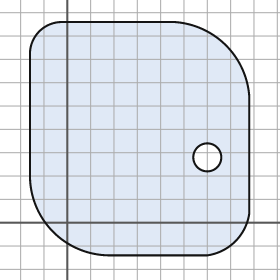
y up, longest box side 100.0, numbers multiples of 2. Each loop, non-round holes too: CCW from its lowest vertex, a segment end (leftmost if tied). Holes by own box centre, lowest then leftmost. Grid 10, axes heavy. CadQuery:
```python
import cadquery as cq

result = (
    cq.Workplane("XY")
    .moveTo(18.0, -14.0)
    .lineTo(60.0, -14.0)
    .threePointArc((72.0, -8.0), (78.0, 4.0))
    .lineTo(78.0, 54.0)
    .threePointArc((68.0, 76.0), (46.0, 86.0))
    .lineTo(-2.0, 86.0)
    .threePointArc((-12.0, 82.0), (-16.0, 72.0))
    .lineTo(-16.0, 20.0)
    .threePointArc((-6.0, -4.0), (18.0, -14.0))
    .close()
    .moveTo(60.0, 28.0)
    .circle(6.0)
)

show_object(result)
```